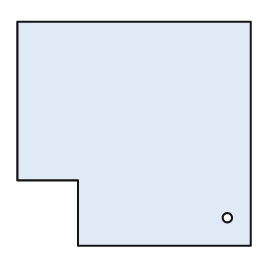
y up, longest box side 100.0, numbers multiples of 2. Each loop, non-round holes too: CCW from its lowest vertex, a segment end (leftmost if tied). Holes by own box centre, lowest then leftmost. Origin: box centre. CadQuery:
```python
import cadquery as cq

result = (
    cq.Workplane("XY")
    .moveTo(-24.0, -48.0)
    .lineTo(50.0, -48.0)
    .lineTo(50.0, 48.0)
    .lineTo(-50.0, 48.0)
    .lineTo(-50.0, -20.0)
    .lineTo(-24.0, -20.0)
    .close()
    .moveTo(40.0, -36.0)
    .circle(2.0)
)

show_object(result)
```